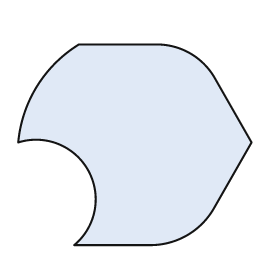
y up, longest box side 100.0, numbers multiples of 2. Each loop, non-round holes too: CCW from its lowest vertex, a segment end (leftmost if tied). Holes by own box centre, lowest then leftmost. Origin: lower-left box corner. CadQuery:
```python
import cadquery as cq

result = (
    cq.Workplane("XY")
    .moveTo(24.0, 0.0)
    .lineTo(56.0, 0.0)
    .threePointArc((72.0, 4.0), (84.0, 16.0))
    .lineTo(100.0, 44.0)
    .lineTo(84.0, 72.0)
    .threePointArc((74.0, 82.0), (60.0, 86.0))
    .lineTo(26.0, 86.0)
    .threePointArc((8.0, 68.0), (0.0, 44.0))
    .threePointArc((30.0, 32.0), (24.0, 0.0))
    .close()
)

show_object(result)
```